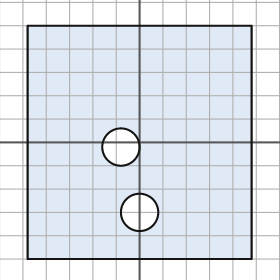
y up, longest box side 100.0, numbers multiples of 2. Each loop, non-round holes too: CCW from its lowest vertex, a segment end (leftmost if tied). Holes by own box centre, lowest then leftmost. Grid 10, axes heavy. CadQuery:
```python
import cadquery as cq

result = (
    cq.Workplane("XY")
    .moveTo(-48.0, -50.0)
    .lineTo(48.0, -50.0)
    .lineTo(48.0, 50.0)
    .lineTo(-48.0, 50.0)
    .close()
    .moveTo(0.0, -30.0)
    .circle(8.0)
    .moveTo(-8.0, -2.0)
    .circle(8.0)
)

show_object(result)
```